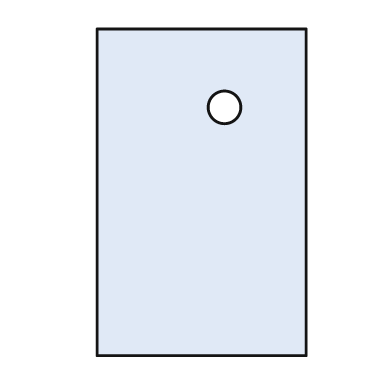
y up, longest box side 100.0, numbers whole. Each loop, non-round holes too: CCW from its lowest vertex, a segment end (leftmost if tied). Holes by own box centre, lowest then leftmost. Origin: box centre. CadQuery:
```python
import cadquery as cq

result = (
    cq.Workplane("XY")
    .moveTo(-32.0, -50.0)
    .lineTo(32.0, -50.0)
    .lineTo(32.0, 50.0)
    .lineTo(-32.0, 50.0)
    .close()
    .moveTo(7.0, 26.0)
    .circle(5.0)
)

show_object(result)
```